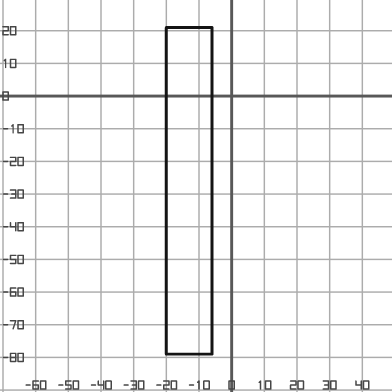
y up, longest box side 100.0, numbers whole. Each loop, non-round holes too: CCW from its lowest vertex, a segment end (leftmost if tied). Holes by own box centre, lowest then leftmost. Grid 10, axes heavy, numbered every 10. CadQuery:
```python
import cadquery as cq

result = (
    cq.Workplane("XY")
    .moveTo(-20.0, -79.0)
    .lineTo(-6.0, -79.0)
    .lineTo(-6.0, 21.0)
    .lineTo(-20.0, 21.0)
    .close()
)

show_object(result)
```